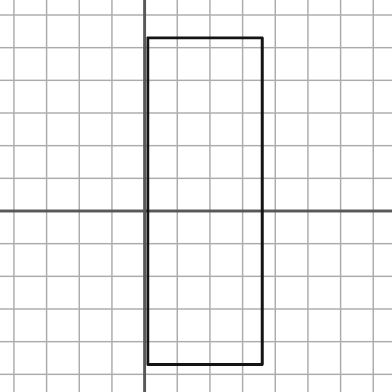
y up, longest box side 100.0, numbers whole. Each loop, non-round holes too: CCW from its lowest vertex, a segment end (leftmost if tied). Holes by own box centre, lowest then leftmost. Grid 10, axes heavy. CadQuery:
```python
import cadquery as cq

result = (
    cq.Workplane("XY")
    .moveTo(1.0, -47.0)
    .lineTo(36.0, -47.0)
    .lineTo(36.0, 53.0)
    .lineTo(1.0, 53.0)
    .close()
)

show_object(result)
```